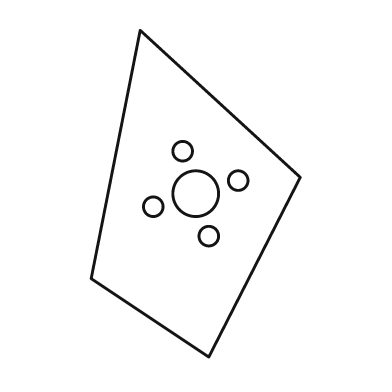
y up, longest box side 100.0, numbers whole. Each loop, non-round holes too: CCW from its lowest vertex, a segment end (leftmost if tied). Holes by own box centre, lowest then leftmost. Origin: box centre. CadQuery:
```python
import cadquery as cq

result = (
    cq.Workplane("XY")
    .moveTo(4.0, -50.0)
    .lineTo(32.0, 5.0)
    .lineTo(-17.0, 50.0)
    .lineTo(-32.0, -26.0)
    .close()
    .moveTo(4.0, -13.0)
    .circle(3.0)
    .moveTo(-13.0, -4.0)
    .circle(3.0)
    .moveTo(0.0, 0.0)
    .circle(7.0)
    .moveTo(13.0, 4.0)
    .circle(3.0)
    .moveTo(-4.0, 13.0)
    .circle(3.0)
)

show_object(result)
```